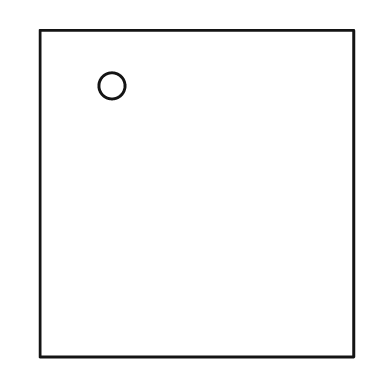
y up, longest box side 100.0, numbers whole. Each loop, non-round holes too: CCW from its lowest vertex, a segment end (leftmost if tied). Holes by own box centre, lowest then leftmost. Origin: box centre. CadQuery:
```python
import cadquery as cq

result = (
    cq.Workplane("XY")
    .moveTo(-48.0, -50.0)
    .lineTo(48.0, -50.0)
    .lineTo(48.0, 50.0)
    .lineTo(-48.0, 50.0)
    .close()
    .moveTo(-26.0, 33.0)
    .circle(4.0)
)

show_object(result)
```